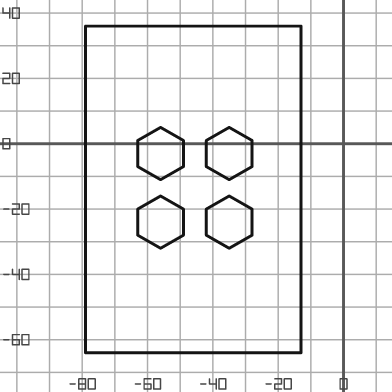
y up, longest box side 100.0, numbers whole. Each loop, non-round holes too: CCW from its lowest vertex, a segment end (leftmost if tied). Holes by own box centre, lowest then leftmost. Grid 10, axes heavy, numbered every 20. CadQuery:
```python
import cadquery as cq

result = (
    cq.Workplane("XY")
    .moveTo(-79.0, -64.0)
    .lineTo(-13.0, -64.0)
    .lineTo(-13.0, 36.0)
    .lineTo(-79.0, 36.0)
    .close()
    .moveTo(-56.0, -32.0)
    .lineTo(-49.0, -28.0)
    .lineTo(-49.0, -20.0)
    .lineTo(-56.0, -16.0)
    .lineTo(-63.0, -20.0)
    .lineTo(-63.0, -28.0)
    .close()
    .moveTo(-35.0, -32.0)
    .lineTo(-28.0, -28.0)
    .lineTo(-28.0, -20.0)
    .lineTo(-35.0, -16.0)
    .lineTo(-42.0, -20.0)
    .lineTo(-42.0, -28.0)
    .close()
    .moveTo(-56.0, -11.0)
    .lineTo(-49.0, -7.0)
    .lineTo(-49.0, 1.0)
    .lineTo(-56.0, 5.0)
    .lineTo(-63.0, 1.0)
    .lineTo(-63.0, -7.0)
    .close()
    .moveTo(-35.0, -11.0)
    .lineTo(-28.0, -7.0)
    .lineTo(-28.0, 1.0)
    .lineTo(-35.0, 5.0)
    .lineTo(-42.0, 1.0)
    .lineTo(-42.0, -7.0)
    .close()
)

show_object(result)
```